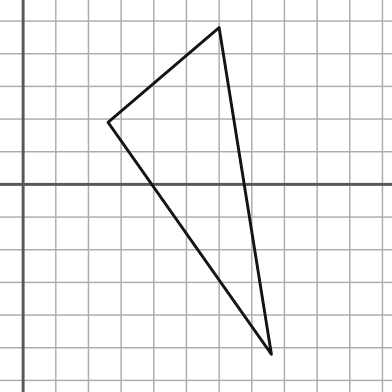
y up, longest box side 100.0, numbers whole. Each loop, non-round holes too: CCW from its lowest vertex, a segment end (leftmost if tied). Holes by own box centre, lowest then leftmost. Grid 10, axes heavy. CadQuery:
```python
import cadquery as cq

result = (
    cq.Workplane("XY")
    .moveTo(76.0, -52.0)
    .lineTo(60.0, 48.0)
    .lineTo(26.0, 19.0)
    .close()
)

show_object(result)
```